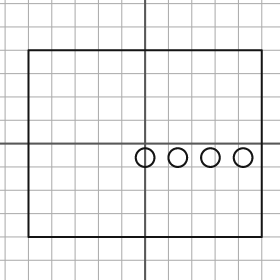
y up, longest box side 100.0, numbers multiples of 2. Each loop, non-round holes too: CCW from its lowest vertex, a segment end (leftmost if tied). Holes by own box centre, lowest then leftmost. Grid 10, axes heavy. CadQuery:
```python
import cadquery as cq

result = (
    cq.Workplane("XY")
    .moveTo(-50.0, -40.0)
    .lineTo(50.0, -40.0)
    .lineTo(50.0, 40.0)
    .lineTo(-50.0, 40.0)
    .close()
    .moveTo(0.0, -6.0)
    .circle(4.0)
    .moveTo(14.0, -6.0)
    .circle(4.0)
    .moveTo(28.0, -6.0)
    .circle(4.0)
    .moveTo(42.0, -6.0)
    .circle(4.0)
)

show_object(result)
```